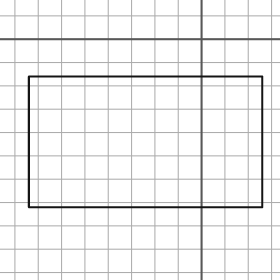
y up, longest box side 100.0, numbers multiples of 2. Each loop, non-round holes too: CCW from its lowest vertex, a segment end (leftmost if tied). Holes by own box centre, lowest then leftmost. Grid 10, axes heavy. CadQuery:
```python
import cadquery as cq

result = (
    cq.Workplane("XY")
    .moveTo(-74.0, -72.0)
    .lineTo(26.0, -72.0)
    .lineTo(26.0, -16.0)
    .lineTo(-74.0, -16.0)
    .close()
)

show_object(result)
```